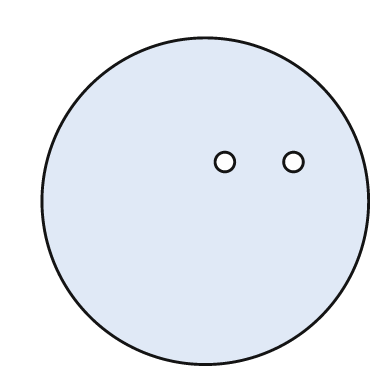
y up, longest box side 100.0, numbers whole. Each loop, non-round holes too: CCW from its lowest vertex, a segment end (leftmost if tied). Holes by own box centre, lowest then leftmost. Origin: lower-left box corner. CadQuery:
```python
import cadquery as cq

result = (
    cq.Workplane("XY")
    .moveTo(50.0, 50.0)
    .circle(50.0)
    .moveTo(56.0, 62.0)
    .circle(3.0)
    .moveTo(77.0, 62.0)
    .circle(3.0)
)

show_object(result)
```